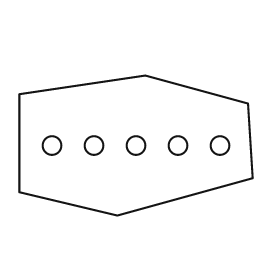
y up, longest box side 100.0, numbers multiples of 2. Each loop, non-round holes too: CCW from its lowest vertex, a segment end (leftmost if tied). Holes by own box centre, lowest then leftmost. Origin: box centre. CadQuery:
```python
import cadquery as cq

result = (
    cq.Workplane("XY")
    .moveTo(-8.0, -30.0)
    .lineTo(50.0, -14.0)
    .lineTo(48.0, 18.0)
    .lineTo(4.0, 30.0)
    .lineTo(-50.0, 22.0)
    .lineTo(-50.0, -20.0)
    .close()
    .moveTo(-36.0, 0.0)
    .circle(4.0)
    .moveTo(-18.0, 0.0)
    .circle(4.0)
    .moveTo(0.0, 0.0)
    .circle(4.0)
    .moveTo(18.0, 0.0)
    .circle(4.0)
    .moveTo(36.0, 0.0)
    .circle(4.0)
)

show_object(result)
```